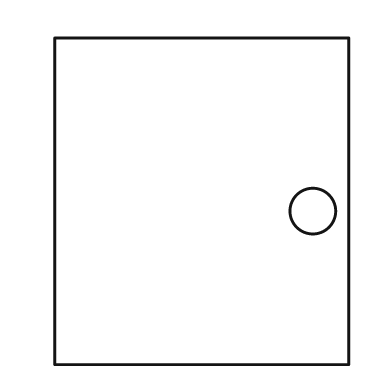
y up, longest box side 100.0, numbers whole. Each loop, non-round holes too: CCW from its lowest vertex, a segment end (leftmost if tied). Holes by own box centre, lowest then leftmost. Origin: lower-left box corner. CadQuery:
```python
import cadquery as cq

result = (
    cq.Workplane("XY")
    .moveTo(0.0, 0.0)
    .lineTo(90.0, 0.0)
    .lineTo(90.0, 100.0)
    .lineTo(0.0, 100.0)
    .close()
    .moveTo(79.0, 47.0)
    .circle(7.0)
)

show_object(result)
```